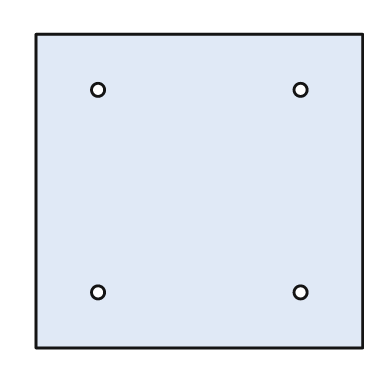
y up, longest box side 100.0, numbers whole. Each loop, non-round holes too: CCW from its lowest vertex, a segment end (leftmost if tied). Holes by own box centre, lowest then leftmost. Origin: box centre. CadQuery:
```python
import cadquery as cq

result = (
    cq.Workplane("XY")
    .moveTo(-50.0, -48.0)
    .lineTo(50.0, -48.0)
    .lineTo(50.0, 48.0)
    .lineTo(-50.0, 48.0)
    .close()
    .moveTo(-31.0, -31.0)
    .circle(2.0)
    .moveTo(31.0, -31.0)
    .circle(2.0)
    .moveTo(-31.0, 31.0)
    .circle(2.0)
    .moveTo(31.0, 31.0)
    .circle(2.0)
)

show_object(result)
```